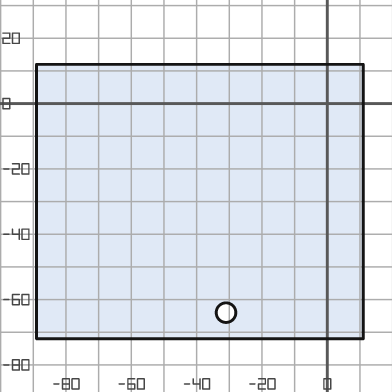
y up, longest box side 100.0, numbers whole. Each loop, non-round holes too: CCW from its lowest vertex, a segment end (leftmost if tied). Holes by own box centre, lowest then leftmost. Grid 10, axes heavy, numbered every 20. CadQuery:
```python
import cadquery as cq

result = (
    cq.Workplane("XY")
    .moveTo(-89.0, -72.0)
    .lineTo(11.0, -72.0)
    .lineTo(11.0, 12.0)
    .lineTo(-89.0, 12.0)
    .close()
    .moveTo(-31.0, -64.0)
    .circle(3.0)
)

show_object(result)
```